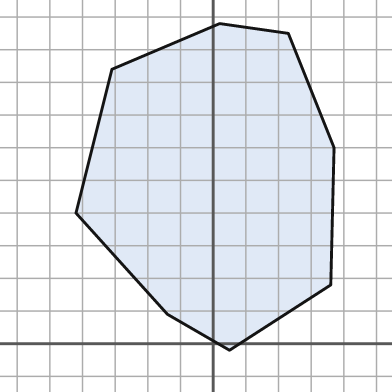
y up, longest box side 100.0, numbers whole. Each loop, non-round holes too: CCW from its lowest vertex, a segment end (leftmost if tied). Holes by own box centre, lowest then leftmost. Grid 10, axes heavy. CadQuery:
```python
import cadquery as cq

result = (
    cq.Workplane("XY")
    .moveTo(5.0, -2.0)
    .lineTo(36.0, 18.0)
    .lineTo(37.0, 60.0)
    .lineTo(23.0, 95.0)
    .lineTo(2.0, 98.0)
    .lineTo(-31.0, 84.0)
    .lineTo(-42.0, 40.0)
    .lineTo(-14.0, 9.0)
    .close()
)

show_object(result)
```